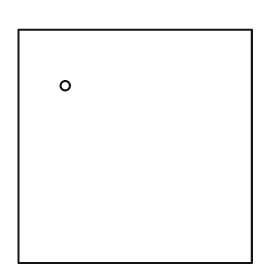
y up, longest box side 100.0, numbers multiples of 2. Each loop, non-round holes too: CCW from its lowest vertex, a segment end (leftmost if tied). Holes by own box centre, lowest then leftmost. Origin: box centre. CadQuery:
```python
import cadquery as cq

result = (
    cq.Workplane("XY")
    .moveTo(-50.0, -50.0)
    .lineTo(50.0, -50.0)
    .lineTo(50.0, 50.0)
    .lineTo(-50.0, 50.0)
    .close()
    .moveTo(-30.0, 26.0)
    .circle(2.0)
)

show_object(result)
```